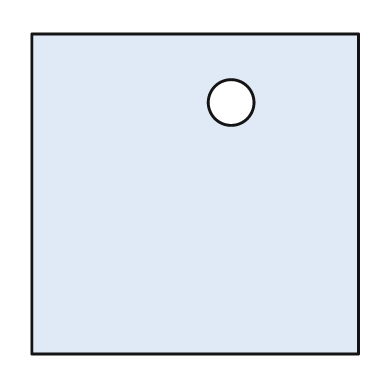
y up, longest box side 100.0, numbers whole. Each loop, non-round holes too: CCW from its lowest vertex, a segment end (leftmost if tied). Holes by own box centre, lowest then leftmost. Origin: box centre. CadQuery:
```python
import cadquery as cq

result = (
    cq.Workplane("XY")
    .moveTo(-50.0, -49.0)
    .lineTo(50.0, -49.0)
    .lineTo(50.0, 49.0)
    .lineTo(-50.0, 49.0)
    .close()
    .moveTo(11.0, 28.0)
    .circle(7.0)
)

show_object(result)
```